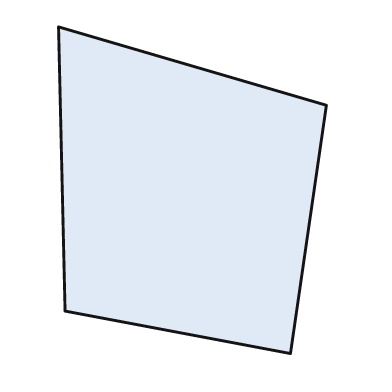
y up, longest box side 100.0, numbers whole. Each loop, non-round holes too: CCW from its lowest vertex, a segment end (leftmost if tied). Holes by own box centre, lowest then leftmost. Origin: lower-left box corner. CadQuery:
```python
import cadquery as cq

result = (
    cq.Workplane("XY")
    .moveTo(71.0, 0.0)
    .lineTo(82.0, 76.0)
    .lineTo(0.0, 100.0)
    .lineTo(2.0, 13.0)
    .close()
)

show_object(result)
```